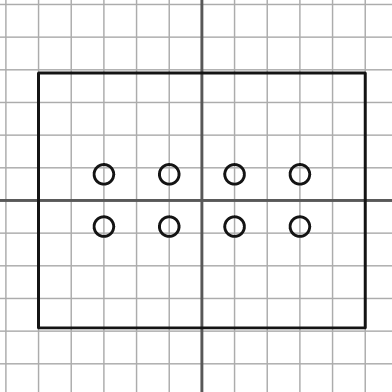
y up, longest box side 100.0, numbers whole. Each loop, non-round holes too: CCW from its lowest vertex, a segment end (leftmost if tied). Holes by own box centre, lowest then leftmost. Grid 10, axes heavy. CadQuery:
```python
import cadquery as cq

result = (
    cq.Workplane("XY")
    .moveTo(-50.0, -39.0)
    .lineTo(50.0, -39.0)
    .lineTo(50.0, 39.0)
    .lineTo(-50.0, 39.0)
    .close()
    .moveTo(-30.0, -8.0)
    .circle(3.0)
    .moveTo(-10.0, -8.0)
    .circle(3.0)
    .moveTo(10.0, -8.0)
    .circle(3.0)
    .moveTo(30.0, -8.0)
    .circle(3.0)
    .moveTo(-30.0, 8.0)
    .circle(3.0)
    .moveTo(-10.0, 8.0)
    .circle(3.0)
    .moveTo(10.0, 8.0)
    .circle(3.0)
    .moveTo(30.0, 8.0)
    .circle(3.0)
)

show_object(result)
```